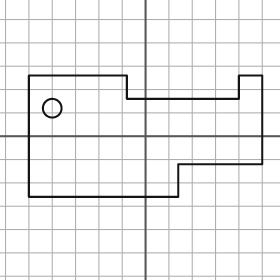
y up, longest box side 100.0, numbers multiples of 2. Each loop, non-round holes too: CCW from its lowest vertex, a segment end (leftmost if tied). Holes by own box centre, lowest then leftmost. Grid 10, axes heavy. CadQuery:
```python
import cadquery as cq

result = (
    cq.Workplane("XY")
    .moveTo(-50.0, -26.0)
    .lineTo(14.0, -26.0)
    .lineTo(14.0, -12.0)
    .lineTo(50.0, -12.0)
    .lineTo(50.0, 26.0)
    .lineTo(40.0, 26.0)
    .lineTo(40.0, 16.0)
    .lineTo(-8.0, 16.0)
    .lineTo(-8.0, 26.0)
    .lineTo(-50.0, 26.0)
    .close()
    .moveTo(-40.0, 12.0)
    .circle(4.0)
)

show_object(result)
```